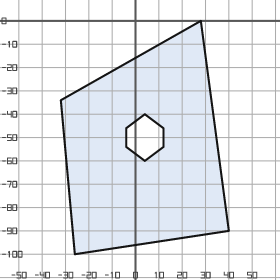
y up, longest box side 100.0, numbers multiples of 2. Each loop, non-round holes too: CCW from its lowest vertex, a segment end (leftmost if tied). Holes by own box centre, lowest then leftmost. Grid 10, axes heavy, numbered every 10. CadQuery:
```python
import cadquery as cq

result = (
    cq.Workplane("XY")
    .moveTo(-26.0, -100.0)
    .lineTo(40.0, -90.0)
    .lineTo(28.0, 0.0)
    .lineTo(-32.0, -34.0)
    .close()
    .moveTo(4.0, -60.0)
    .lineTo(12.0, -54.0)
    .lineTo(12.0, -46.0)
    .lineTo(4.0, -40.0)
    .lineTo(-4.0, -46.0)
    .lineTo(-4.0, -54.0)
    .close()
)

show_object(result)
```